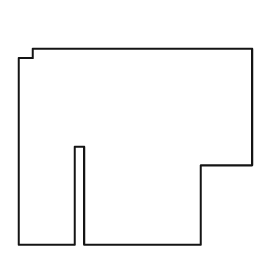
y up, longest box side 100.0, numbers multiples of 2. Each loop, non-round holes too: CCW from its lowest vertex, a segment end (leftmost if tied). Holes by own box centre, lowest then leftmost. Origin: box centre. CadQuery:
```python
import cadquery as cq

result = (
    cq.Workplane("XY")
    .moveTo(-50.0, -42.0)
    .lineTo(-26.0, -42.0)
    .lineTo(-26.0, 0.0)
    .lineTo(-22.0, 0.0)
    .lineTo(-22.0, -42.0)
    .lineTo(28.0, -42.0)
    .lineTo(28.0, -8.0)
    .lineTo(50.0, -8.0)
    .lineTo(50.0, 42.0)
    .lineTo(-44.0, 42.0)
    .lineTo(-44.0, 38.0)
    .lineTo(-50.0, 38.0)
    .close()
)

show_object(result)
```